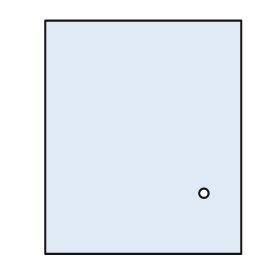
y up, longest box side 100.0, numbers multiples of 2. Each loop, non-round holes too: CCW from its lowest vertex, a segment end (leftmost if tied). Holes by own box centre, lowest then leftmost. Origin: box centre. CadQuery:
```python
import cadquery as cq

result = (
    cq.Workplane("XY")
    .moveTo(-42.0, -50.0)
    .lineTo(42.0, -50.0)
    .lineTo(42.0, 50.0)
    .lineTo(-42.0, 50.0)
    .close()
    .moveTo(26.0, -24.0)
    .circle(2.0)
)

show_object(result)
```